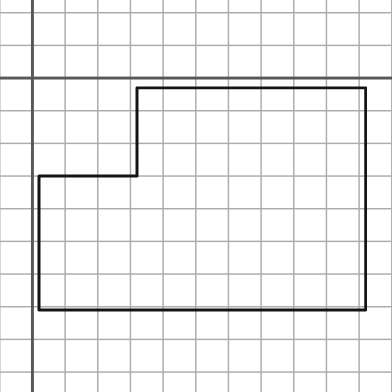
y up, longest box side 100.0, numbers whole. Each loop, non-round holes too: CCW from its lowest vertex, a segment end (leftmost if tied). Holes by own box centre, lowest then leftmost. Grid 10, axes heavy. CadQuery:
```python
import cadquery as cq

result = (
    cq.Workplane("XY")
    .moveTo(2.0, -71.0)
    .lineTo(102.0, -71.0)
    .lineTo(102.0, -3.0)
    .lineTo(32.0, -3.0)
    .lineTo(32.0, -30.0)
    .lineTo(2.0, -30.0)
    .close()
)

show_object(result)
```